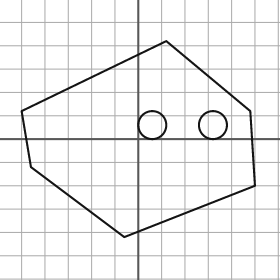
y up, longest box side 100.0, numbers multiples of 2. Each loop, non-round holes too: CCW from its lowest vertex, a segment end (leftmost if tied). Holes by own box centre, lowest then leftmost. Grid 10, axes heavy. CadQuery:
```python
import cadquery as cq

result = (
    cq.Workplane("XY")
    .moveTo(-6.0, -42.0)
    .lineTo(50.0, -20.0)
    .lineTo(48.0, 12.0)
    .lineTo(12.0, 42.0)
    .lineTo(-50.0, 12.0)
    .lineTo(-46.0, -12.0)
    .close()
    .moveTo(6.0, 6.0)
    .circle(6.0)
    .moveTo(32.0, 6.0)
    .circle(6.0)
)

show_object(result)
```